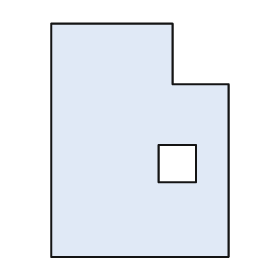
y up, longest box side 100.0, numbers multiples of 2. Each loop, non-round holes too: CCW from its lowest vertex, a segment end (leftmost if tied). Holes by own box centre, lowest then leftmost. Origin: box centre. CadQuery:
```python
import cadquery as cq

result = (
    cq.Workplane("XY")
    .moveTo(-38.0, -50.0)
    .lineTo(38.0, -50.0)
    .lineTo(38.0, 24.0)
    .lineTo(14.0, 24.0)
    .lineTo(14.0, 50.0)
    .lineTo(-38.0, 50.0)
    .close()
    .moveTo(8.0, -18.0)
    .lineTo(24.0, -18.0)
    .lineTo(24.0, -2.0)
    .lineTo(8.0, -2.0)
    .close()
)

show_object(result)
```